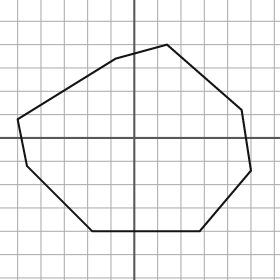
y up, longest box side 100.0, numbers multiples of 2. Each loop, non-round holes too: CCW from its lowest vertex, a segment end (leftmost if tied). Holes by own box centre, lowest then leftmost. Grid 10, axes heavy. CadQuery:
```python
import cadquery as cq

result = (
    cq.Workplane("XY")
    .moveTo(-18.0, -40.0)
    .lineTo(28.0, -40.0)
    .lineTo(50.0, -14.0)
    .lineTo(46.0, 12.0)
    .lineTo(14.0, 40.0)
    .lineTo(-8.0, 34.0)
    .lineTo(-50.0, 8.0)
    .lineTo(-46.0, -12.0)
    .close()
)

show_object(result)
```